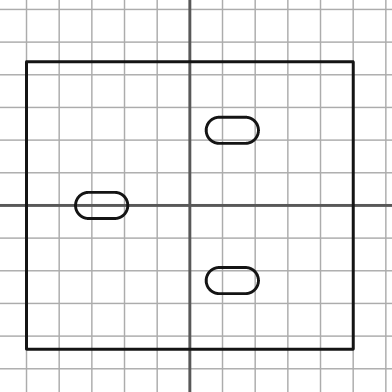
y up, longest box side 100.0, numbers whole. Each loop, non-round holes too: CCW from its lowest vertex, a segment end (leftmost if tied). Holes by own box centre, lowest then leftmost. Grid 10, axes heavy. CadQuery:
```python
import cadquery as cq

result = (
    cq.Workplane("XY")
    .moveTo(-50.0, -44.0)
    .lineTo(50.0, -44.0)
    .lineTo(50.0, 44.0)
    .lineTo(-50.0, 44.0)
    .close()
    .moveTo(9.0, -27.0)
    .lineTo(17.0, -27.0)
    .threePointArc((21.0, -23.0), (17.0, -19.0))
    .lineTo(9.0, -19.0)
    .threePointArc((5.0, -23.0), (9.0, -27.0))
    .close()
    .moveTo(-31.0, -4.0)
    .lineTo(-23.0, -4.0)
    .threePointArc((-19.0, 0.0), (-23.0, 4.0))
    .lineTo(-31.0, 4.0)
    .threePointArc((-35.0, 0.0), (-31.0, -4.0))
    .close()
    .moveTo(9.0, 19.0)
    .lineTo(17.0, 19.0)
    .threePointArc((21.0, 23.0), (17.0, 27.0))
    .lineTo(9.0, 27.0)
    .threePointArc((5.0, 23.0), (9.0, 19.0))
    .close()
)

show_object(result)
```